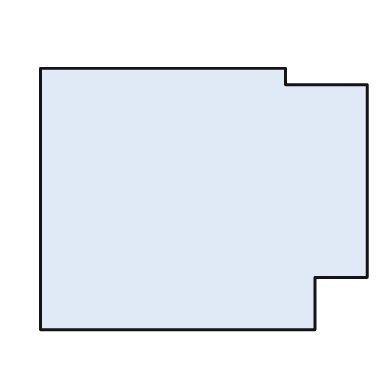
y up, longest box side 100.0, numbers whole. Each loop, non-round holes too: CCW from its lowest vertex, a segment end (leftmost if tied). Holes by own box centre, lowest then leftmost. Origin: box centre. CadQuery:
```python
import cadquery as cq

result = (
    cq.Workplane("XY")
    .moveTo(-50.0, -40.0)
    .lineTo(34.0, -40.0)
    .lineTo(34.0, -24.0)
    .lineTo(50.0, -24.0)
    .lineTo(50.0, 35.0)
    .lineTo(25.0, 35.0)
    .lineTo(25.0, 40.0)
    .lineTo(-50.0, 40.0)
    .close()
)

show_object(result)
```